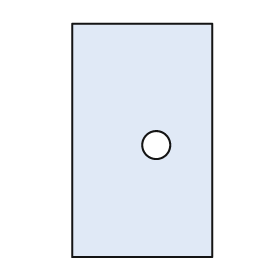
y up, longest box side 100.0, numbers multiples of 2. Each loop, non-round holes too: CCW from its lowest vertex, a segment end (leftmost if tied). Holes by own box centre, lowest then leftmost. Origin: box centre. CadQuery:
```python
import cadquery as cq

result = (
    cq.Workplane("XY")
    .moveTo(-30.0, -50.0)
    .lineTo(30.0, -50.0)
    .lineTo(30.0, 50.0)
    .lineTo(-30.0, 50.0)
    .close()
    .moveTo(6.0, -2.0)
    .circle(6.0)
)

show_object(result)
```